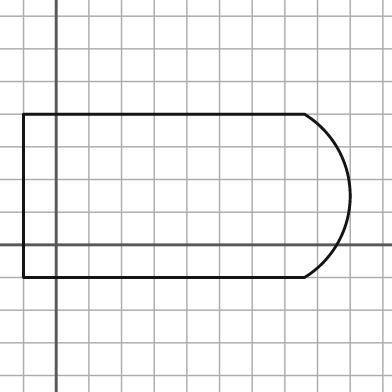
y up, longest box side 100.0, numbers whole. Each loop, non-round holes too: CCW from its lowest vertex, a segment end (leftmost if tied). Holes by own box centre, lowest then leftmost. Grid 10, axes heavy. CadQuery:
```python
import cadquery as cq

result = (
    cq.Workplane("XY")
    .moveTo(-10.0, -10.0)
    .lineTo(76.0, -10.0)
    .threePointArc((90.0, 15.0), (76.0, 40.0))
    .lineTo(-10.0, 40.0)
    .close()
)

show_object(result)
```